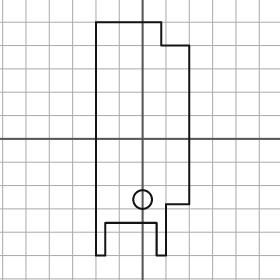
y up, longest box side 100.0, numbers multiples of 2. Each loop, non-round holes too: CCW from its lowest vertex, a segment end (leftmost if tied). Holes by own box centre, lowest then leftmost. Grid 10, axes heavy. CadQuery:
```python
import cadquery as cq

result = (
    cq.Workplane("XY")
    .moveTo(-20.0, -50.0)
    .lineTo(-16.0, -50.0)
    .lineTo(-16.0, -36.0)
    .lineTo(6.0, -36.0)
    .lineTo(6.0, -50.0)
    .lineTo(10.0, -50.0)
    .lineTo(10.0, -28.0)
    .lineTo(20.0, -28.0)
    .lineTo(20.0, 40.0)
    .lineTo(8.0, 40.0)
    .lineTo(8.0, 50.0)
    .lineTo(-20.0, 50.0)
    .close()
    .moveTo(0.0, -26.0)
    .circle(4.0)
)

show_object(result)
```